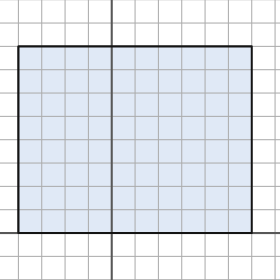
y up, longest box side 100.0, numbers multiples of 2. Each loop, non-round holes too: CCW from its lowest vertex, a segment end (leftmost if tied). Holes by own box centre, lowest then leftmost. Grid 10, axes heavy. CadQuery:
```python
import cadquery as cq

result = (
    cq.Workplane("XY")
    .moveTo(-40.0, 0.0)
    .lineTo(60.0, 0.0)
    .lineTo(60.0, 80.0)
    .lineTo(-40.0, 80.0)
    .close()
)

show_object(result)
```